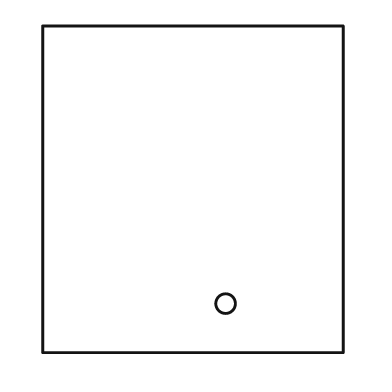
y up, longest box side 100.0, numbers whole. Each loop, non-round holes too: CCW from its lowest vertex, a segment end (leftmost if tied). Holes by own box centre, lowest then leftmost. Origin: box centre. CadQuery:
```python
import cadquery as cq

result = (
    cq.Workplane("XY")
    .moveTo(-46.0, -50.0)
    .lineTo(46.0, -50.0)
    .lineTo(46.0, 50.0)
    .lineTo(-46.0, 50.0)
    .close()
    .moveTo(10.0, -35.0)
    .circle(3.0)
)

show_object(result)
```